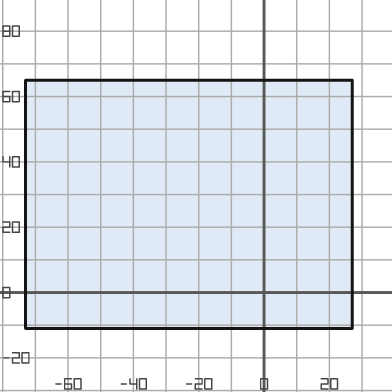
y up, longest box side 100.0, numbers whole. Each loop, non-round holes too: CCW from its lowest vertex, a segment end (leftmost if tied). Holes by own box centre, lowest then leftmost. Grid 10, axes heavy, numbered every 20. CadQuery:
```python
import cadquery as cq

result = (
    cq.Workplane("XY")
    .moveTo(-73.0, -11.0)
    .lineTo(27.0, -11.0)
    .lineTo(27.0, 65.0)
    .lineTo(-73.0, 65.0)
    .close()
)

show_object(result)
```